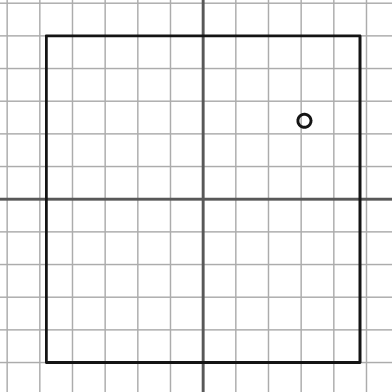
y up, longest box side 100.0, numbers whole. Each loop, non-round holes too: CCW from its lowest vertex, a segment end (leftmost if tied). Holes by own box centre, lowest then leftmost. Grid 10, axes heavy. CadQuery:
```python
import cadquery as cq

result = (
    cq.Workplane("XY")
    .moveTo(-48.0, -50.0)
    .lineTo(48.0, -50.0)
    .lineTo(48.0, 50.0)
    .lineTo(-48.0, 50.0)
    .close()
    .moveTo(31.0, 24.0)
    .circle(2.0)
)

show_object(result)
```